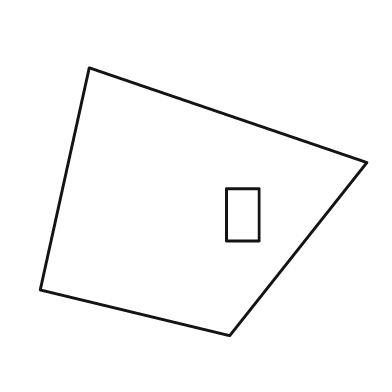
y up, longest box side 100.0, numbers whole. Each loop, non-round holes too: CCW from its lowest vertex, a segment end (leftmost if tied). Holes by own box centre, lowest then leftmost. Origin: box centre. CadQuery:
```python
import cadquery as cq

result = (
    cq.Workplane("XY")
    .moveTo(8.0, -41.0)
    .lineTo(50.0, 12.0)
    .lineTo(-35.0, 41.0)
    .lineTo(-50.0, -27.0)
    .close()
    .moveTo(7.0, -12.0)
    .lineTo(17.0, -12.0)
    .lineTo(17.0, 4.0)
    .lineTo(7.0, 4.0)
    .close()
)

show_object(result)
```